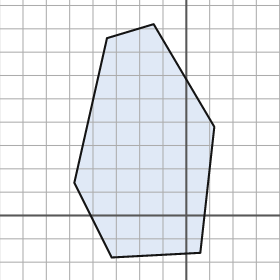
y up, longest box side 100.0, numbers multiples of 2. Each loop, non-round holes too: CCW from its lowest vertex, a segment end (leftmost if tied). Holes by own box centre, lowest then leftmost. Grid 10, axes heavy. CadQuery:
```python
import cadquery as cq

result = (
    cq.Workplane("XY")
    .moveTo(-32.0, -18.0)
    .lineTo(6.0, -16.0)
    .lineTo(12.0, 38.0)
    .lineTo(-14.0, 82.0)
    .lineTo(-34.0, 76.0)
    .lineTo(-48.0, 14.0)
    .close()
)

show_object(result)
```